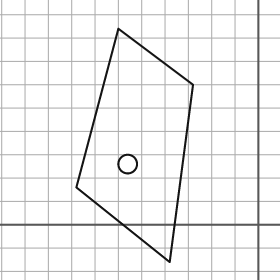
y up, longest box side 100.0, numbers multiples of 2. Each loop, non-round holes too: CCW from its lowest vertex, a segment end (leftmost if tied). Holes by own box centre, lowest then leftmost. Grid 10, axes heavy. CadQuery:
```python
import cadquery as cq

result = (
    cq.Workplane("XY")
    .moveTo(-38.0, -16.0)
    .lineTo(-28.0, 60.0)
    .lineTo(-60.0, 84.0)
    .lineTo(-78.0, 16.0)
    .close()
    .moveTo(-56.0, 26.0)
    .circle(4.0)
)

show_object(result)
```